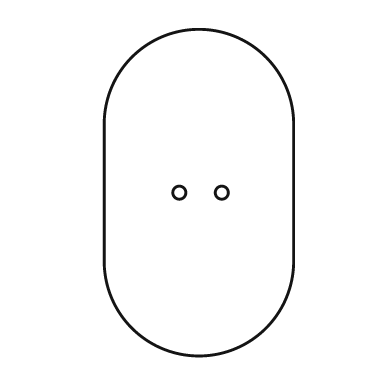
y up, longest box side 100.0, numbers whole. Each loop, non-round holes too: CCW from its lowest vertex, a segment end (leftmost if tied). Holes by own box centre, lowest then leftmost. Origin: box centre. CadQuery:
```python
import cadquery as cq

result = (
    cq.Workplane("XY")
    .moveTo(-29.0, -21.0)
    .threePointArc((0.0, -50.0), (29.0, -21.0))
    .lineTo(29.0, 21.0)
    .threePointArc((0.0, 50.0), (-29.0, 21.0))
    .close()
    .moveTo(-6.0, 0.0)
    .circle(2.0)
    .moveTo(7.0, 0.0)
    .circle(2.0)
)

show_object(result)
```